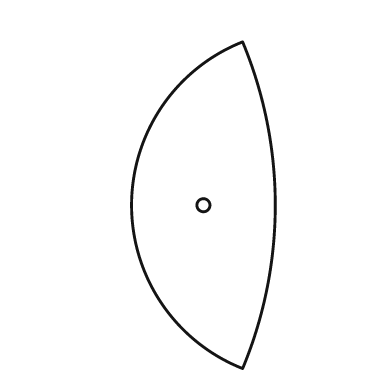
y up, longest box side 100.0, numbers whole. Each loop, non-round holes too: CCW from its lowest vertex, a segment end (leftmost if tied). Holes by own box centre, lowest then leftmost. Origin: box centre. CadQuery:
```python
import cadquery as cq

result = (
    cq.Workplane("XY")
    .moveTo(12.0, -50.0)
    .threePointArc((22.0, 0.0), (12.0, 50.0))
    .threePointArc((-22.0, 0.0), (12.0, -50.0))
    .close()
    .moveTo(0.0, 0.0)
    .circle(2.0)
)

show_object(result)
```